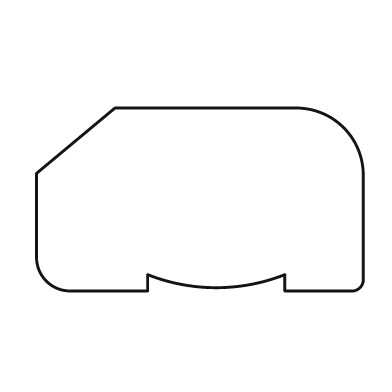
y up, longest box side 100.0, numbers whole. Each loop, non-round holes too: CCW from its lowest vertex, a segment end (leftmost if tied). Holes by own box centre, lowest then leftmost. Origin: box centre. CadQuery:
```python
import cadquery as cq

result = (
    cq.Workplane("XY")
    .moveTo(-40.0, -28.0)
    .lineTo(-16.0, -28.0)
    .lineTo(-16.0, -23.0)
    .threePointArc((5.0, -27.0), (26.0, -23.0))
    .lineTo(26.0, -28.0)
    .lineTo(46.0, -28.0)
    .threePointArc((49.0, -27.0), (50.0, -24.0))
    .lineTo(50.0, 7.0)
    .threePointArc((44.0, 22.0), (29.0, 28.0))
    .lineTo(-26.0, 28.0)
    .lineTo(-50.0, 8.0)
    .lineTo(-50.0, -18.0)
    .threePointArc((-47.0, -25.0), (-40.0, -28.0))
    .close()
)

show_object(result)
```